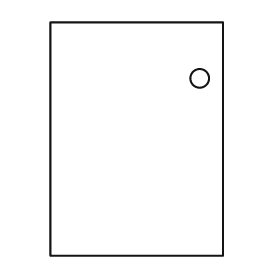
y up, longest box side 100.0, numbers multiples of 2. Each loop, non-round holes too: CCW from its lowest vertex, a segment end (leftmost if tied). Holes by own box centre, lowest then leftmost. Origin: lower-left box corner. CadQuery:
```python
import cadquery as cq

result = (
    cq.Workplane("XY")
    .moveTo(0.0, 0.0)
    .lineTo(74.0, 0.0)
    .lineTo(74.0, 100.0)
    .lineTo(0.0, 100.0)
    .close()
    .moveTo(64.0, 76.0)
    .circle(4.0)
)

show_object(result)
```